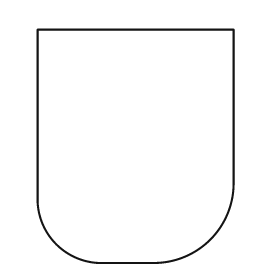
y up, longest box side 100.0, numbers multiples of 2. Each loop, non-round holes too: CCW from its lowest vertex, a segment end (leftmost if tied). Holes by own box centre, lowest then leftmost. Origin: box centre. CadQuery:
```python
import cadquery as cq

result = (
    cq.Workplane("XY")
    .moveTo(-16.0, -50.0)
    .lineTo(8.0, -50.0)
    .threePointArc((32.0, -40.0), (42.0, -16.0))
    .lineTo(42.0, 50.0)
    .lineTo(-42.0, 50.0)
    .lineTo(-42.0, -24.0)
    .threePointArc((-34.0, -42.0), (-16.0, -50.0))
    .close()
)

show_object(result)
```